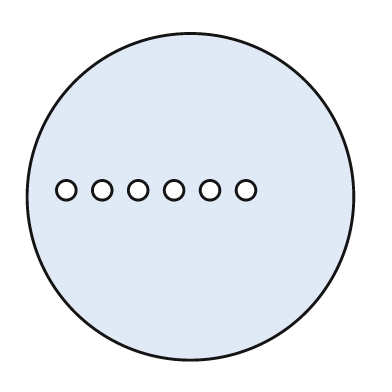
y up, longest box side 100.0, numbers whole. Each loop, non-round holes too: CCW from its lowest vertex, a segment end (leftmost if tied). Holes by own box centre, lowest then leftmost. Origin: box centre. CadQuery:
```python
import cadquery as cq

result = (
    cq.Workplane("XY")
    .moveTo(0.0, 0.0)
    .circle(50.0)
    .moveTo(-38.0, 2.0)
    .circle(3.0)
    .moveTo(-27.0, 2.0)
    .circle(3.0)
    .moveTo(-16.0, 2.0)
    .circle(3.0)
    .moveTo(-5.0, 2.0)
    .circle(3.0)
    .moveTo(6.0, 2.0)
    .circle(3.0)
    .moveTo(17.0, 2.0)
    .circle(3.0)
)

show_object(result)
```